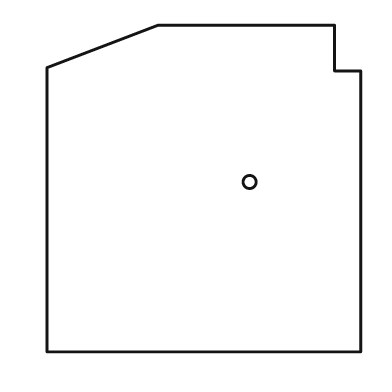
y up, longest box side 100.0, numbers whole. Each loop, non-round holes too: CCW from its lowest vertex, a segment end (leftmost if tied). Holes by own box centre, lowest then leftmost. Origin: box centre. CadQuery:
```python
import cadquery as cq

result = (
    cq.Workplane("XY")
    .moveTo(-48.0, -50.0)
    .lineTo(48.0, -50.0)
    .lineTo(48.0, 36.0)
    .lineTo(40.0, 36.0)
    .lineTo(40.0, 50.0)
    .lineTo(-14.0, 50.0)
    .lineTo(-48.0, 37.0)
    .close()
    .moveTo(14.0, 2.0)
    .circle(2.0)
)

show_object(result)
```